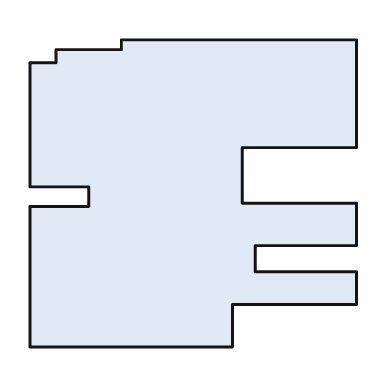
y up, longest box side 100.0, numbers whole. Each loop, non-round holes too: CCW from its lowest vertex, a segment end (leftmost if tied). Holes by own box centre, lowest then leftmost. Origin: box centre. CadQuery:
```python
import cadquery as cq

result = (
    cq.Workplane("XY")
    .moveTo(-50.0, -47.0)
    .lineTo(12.0, -47.0)
    .lineTo(12.0, -34.0)
    .lineTo(50.0, -34.0)
    .lineTo(50.0, -24.0)
    .lineTo(19.0, -24.0)
    .lineTo(19.0, -16.0)
    .lineTo(50.0, -16.0)
    .lineTo(50.0, -3.0)
    .lineTo(15.0, -3.0)
    .lineTo(15.0, 14.0)
    .lineTo(50.0, 14.0)
    .lineTo(50.0, 47.0)
    .lineTo(-22.0, 47.0)
    .lineTo(-22.0, 44.0)
    .lineTo(-42.0, 44.0)
    .lineTo(-42.0, 40.0)
    .lineTo(-50.0, 40.0)
    .lineTo(-50.0, 2.0)
    .lineTo(-32.0, 2.0)
    .lineTo(-32.0, -4.0)
    .lineTo(-50.0, -4.0)
    .close()
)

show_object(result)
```